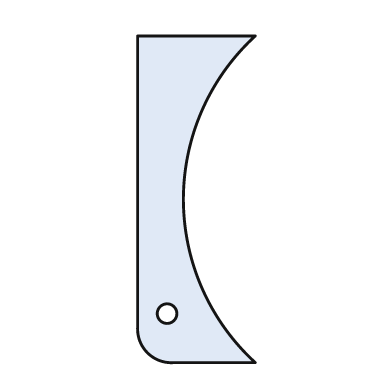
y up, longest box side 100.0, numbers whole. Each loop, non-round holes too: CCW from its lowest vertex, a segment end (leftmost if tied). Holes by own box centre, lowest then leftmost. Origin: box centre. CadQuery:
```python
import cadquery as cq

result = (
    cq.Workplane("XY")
    .moveTo(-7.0, -50.0)
    .lineTo(18.0, -50.0)
    .threePointArc((-4.0, 0.0), (18.0, 50.0))
    .lineTo(-18.0, 50.0)
    .lineTo(-18.0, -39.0)
    .threePointArc((-15.0, -47.0), (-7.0, -50.0))
    .close()
    .moveTo(-9.0, -35.0)
    .circle(3.0)
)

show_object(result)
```